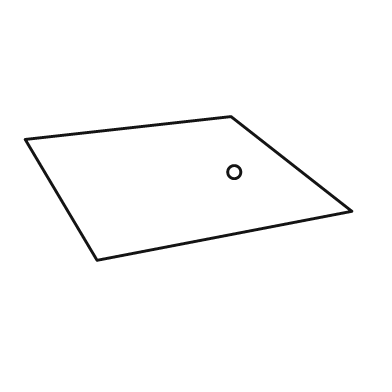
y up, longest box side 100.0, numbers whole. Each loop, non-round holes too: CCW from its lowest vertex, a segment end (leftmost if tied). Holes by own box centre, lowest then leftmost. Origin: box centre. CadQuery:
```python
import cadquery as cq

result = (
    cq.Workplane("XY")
    .moveTo(-28.0, -22.0)
    .lineTo(50.0, -7.0)
    .lineTo(13.0, 22.0)
    .lineTo(-50.0, 15.0)
    .close()
    .moveTo(14.0, 5.0)
    .circle(2.0)
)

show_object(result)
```